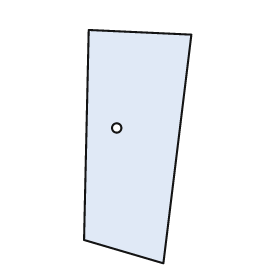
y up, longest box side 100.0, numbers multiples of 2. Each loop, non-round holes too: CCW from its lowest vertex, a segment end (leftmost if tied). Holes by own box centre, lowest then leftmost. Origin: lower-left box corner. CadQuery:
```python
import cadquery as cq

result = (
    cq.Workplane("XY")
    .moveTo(34.0, 0.0)
    .lineTo(46.0, 98.0)
    .lineTo(2.0, 100.0)
    .lineTo(0.0, 10.0)
    .close()
    .moveTo(14.0, 58.0)
    .circle(2.0)
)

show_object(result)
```